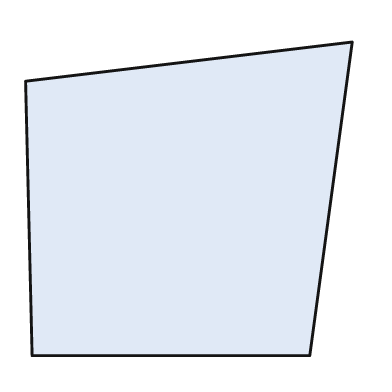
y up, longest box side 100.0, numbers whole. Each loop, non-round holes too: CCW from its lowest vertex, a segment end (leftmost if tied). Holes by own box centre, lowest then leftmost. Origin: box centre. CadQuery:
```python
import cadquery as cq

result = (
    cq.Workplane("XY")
    .moveTo(-48.0, -48.0)
    .lineTo(37.0, -48.0)
    .lineTo(50.0, 48.0)
    .lineTo(-50.0, 36.0)
    .close()
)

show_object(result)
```